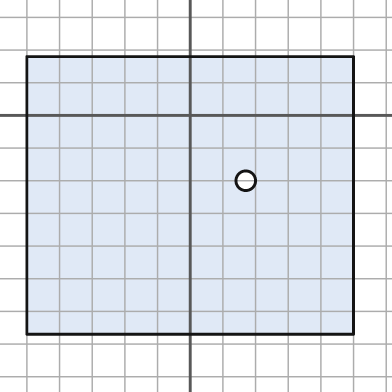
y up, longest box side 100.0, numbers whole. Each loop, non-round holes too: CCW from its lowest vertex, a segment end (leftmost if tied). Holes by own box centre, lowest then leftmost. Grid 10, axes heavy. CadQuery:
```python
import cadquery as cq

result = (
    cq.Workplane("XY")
    .moveTo(-50.0, -67.0)
    .lineTo(50.0, -67.0)
    .lineTo(50.0, 18.0)
    .lineTo(-50.0, 18.0)
    .close()
    .moveTo(17.0, -20.0)
    .circle(3.0)
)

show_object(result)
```